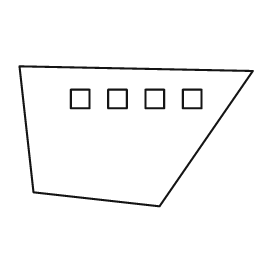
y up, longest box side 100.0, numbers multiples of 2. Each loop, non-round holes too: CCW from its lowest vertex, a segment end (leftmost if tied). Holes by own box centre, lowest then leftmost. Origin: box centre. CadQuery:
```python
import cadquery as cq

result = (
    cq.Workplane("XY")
    .moveTo(10.0, -30.0)
    .lineTo(50.0, 28.0)
    .lineTo(-50.0, 30.0)
    .lineTo(-44.0, -24.0)
    .close()
    .moveTo(-28.0, 12.0)
    .lineTo(-20.0, 12.0)
    .lineTo(-20.0, 20.0)
    .lineTo(-28.0, 20.0)
    .close()
    .moveTo(-12.0, 12.0)
    .lineTo(-4.0, 12.0)
    .lineTo(-4.0, 20.0)
    .lineTo(-12.0, 20.0)
    .close()
    .moveTo(4.0, 12.0)
    .lineTo(12.0, 12.0)
    .lineTo(12.0, 20.0)
    .lineTo(4.0, 20.0)
    .close()
    .moveTo(20.0, 12.0)
    .lineTo(28.0, 12.0)
    .lineTo(28.0, 20.0)
    .lineTo(20.0, 20.0)
    .close()
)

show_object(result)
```